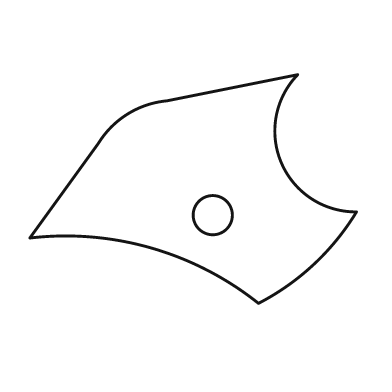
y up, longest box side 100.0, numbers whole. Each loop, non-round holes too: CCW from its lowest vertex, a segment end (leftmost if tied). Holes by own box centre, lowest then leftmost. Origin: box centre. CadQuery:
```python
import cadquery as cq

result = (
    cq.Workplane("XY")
    .moveTo(20.0, -35.0)
    .threePointArc((37.0, -23.0), (50.0, -7.0))
    .threePointArc((27.0, 8.0), (32.0, 35.0))
    .lineTo(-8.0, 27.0)
    .threePointArc((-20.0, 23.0), (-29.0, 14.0))
    .lineTo(-50.0, -15.0)
    .threePointArc((-13.0, -18.0), (20.0, -35.0))
    .close()
    .moveTo(6.0, -8.0)
    .circle(6.0)
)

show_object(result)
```